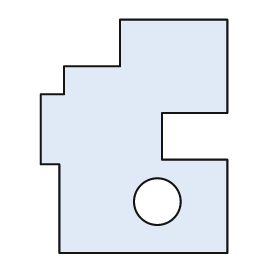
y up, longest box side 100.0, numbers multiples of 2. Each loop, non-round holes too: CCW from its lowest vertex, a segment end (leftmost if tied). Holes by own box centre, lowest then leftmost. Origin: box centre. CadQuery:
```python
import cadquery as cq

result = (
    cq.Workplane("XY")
    .moveTo(-32.0, -50.0)
    .lineTo(40.0, -50.0)
    .lineTo(40.0, -10.0)
    .lineTo(12.0, -10.0)
    .lineTo(12.0, 10.0)
    .lineTo(40.0, 10.0)
    .lineTo(40.0, 50.0)
    .lineTo(-6.0, 50.0)
    .lineTo(-6.0, 30.0)
    .lineTo(-30.0, 30.0)
    .lineTo(-30.0, 18.0)
    .lineTo(-40.0, 18.0)
    .lineTo(-40.0, -12.0)
    .lineTo(-32.0, -12.0)
    .close()
    .moveTo(10.0, -28.0)
    .circle(10.0)
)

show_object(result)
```